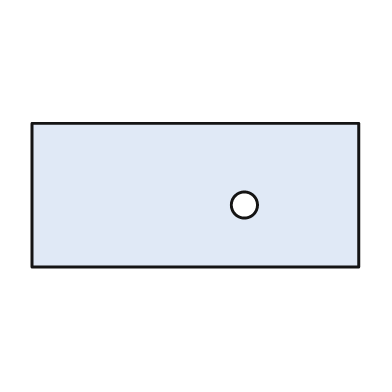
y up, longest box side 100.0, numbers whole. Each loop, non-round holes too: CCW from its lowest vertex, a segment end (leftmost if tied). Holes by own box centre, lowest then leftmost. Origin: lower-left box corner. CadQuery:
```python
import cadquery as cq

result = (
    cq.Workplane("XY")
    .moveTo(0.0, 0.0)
    .lineTo(100.0, 0.0)
    .lineTo(100.0, 44.0)
    .lineTo(0.0, 44.0)
    .close()
    .moveTo(65.0, 19.0)
    .circle(4.0)
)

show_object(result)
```